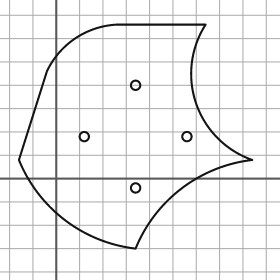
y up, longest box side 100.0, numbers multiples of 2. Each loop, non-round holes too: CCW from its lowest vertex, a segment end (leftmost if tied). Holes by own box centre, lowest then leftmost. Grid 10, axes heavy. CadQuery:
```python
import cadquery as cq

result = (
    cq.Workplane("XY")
    .moveTo(34.0, -30.0)
    .threePointArc((54.0, -4.0), (84.0, 8.0))
    .threePointArc((60.0, 32.0), (64.0, 66.0))
    .lineTo(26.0, 66.0)
    .threePointArc((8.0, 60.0), (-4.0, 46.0))
    .lineTo(-16.0, 8.0)
    .threePointArc((4.0, -18.0), (34.0, -30.0))
    .close()
    .moveTo(34.0, -4.0)
    .circle(2.0)
    .moveTo(12.0, 18.0)
    .circle(2.0)
    .moveTo(56.0, 18.0)
    .circle(2.0)
    .moveTo(34.0, 40.0)
    .circle(2.0)
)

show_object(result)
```